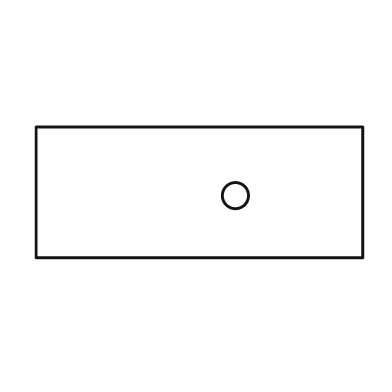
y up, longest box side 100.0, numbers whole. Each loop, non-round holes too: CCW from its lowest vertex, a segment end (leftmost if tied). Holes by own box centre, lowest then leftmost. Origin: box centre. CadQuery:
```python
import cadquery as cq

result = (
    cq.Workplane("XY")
    .moveTo(-50.0, -20.0)
    .lineTo(50.0, -20.0)
    .lineTo(50.0, 20.0)
    .lineTo(-50.0, 20.0)
    .close()
    .moveTo(11.0, -1.0)
    .circle(4.0)
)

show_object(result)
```